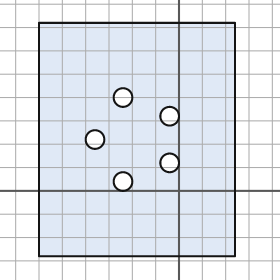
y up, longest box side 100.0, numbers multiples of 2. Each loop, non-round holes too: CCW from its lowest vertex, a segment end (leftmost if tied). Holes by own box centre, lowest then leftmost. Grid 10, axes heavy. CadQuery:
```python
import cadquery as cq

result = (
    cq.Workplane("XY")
    .moveTo(-60.0, -28.0)
    .lineTo(24.0, -28.0)
    .lineTo(24.0, 72.0)
    .lineTo(-60.0, 72.0)
    .close()
    .moveTo(-24.0, 4.0)
    .circle(4.0)
    .moveTo(-4.0, 12.0)
    .circle(4.0)
    .moveTo(-36.0, 22.0)
    .circle(4.0)
    .moveTo(-4.0, 32.0)
    .circle(4.0)
    .moveTo(-24.0, 40.0)
    .circle(4.0)
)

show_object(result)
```